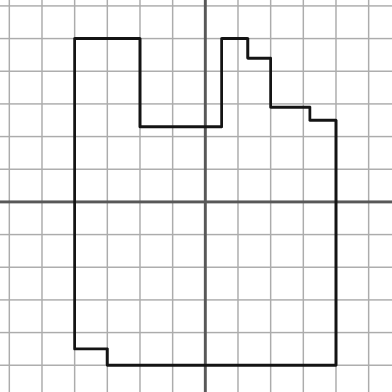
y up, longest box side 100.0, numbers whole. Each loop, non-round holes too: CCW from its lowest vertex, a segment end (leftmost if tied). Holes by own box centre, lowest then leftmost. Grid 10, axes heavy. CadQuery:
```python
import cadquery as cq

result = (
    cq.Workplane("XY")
    .moveTo(-30.0, -50.0)
    .lineTo(40.0, -50.0)
    .lineTo(40.0, 25.0)
    .lineTo(32.0, 25.0)
    .lineTo(32.0, 29.0)
    .lineTo(20.0, 29.0)
    .lineTo(20.0, 44.0)
    .lineTo(13.0, 44.0)
    .lineTo(13.0, 50.0)
    .lineTo(5.0, 50.0)
    .lineTo(5.0, 23.0)
    .lineTo(-20.0, 23.0)
    .lineTo(-20.0, 50.0)
    .lineTo(-40.0, 50.0)
    .lineTo(-40.0, -45.0)
    .lineTo(-30.0, -45.0)
    .close()
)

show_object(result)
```